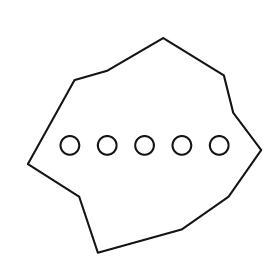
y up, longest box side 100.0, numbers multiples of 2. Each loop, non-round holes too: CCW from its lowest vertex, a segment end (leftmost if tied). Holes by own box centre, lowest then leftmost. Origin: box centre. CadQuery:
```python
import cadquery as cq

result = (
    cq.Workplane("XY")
    .moveTo(-20.0, -46.0)
    .lineTo(16.0, -36.0)
    .lineTo(36.0, -22.0)
    .lineTo(50.0, -2.0)
    .lineTo(38.0, 14.0)
    .lineTo(34.0, 30.0)
    .lineTo(8.0, 46.0)
    .lineTo(-16.0, 32.0)
    .lineTo(-30.0, 28.0)
    .lineTo(-50.0, -8.0)
    .lineTo(-28.0, -22.0)
    .close()
    .moveTo(-32.0, 0.0)
    .circle(4.0)
    .moveTo(-16.0, 0.0)
    .circle(4.0)
    .moveTo(0.0, 0.0)
    .circle(4.0)
    .moveTo(16.0, 0.0)
    .circle(4.0)
    .moveTo(32.0, 0.0)
    .circle(4.0)
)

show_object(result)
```